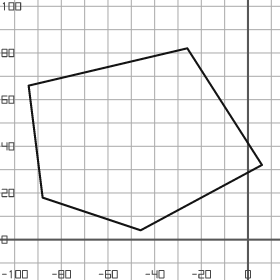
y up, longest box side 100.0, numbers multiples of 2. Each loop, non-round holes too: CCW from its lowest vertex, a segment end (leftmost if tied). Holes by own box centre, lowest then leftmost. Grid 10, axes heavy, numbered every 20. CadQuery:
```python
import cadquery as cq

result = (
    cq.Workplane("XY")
    .moveTo(-46.0, 4.0)
    .lineTo(6.0, 32.0)
    .lineTo(-26.0, 82.0)
    .lineTo(-94.0, 66.0)
    .lineTo(-88.0, 18.0)
    .close()
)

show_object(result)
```